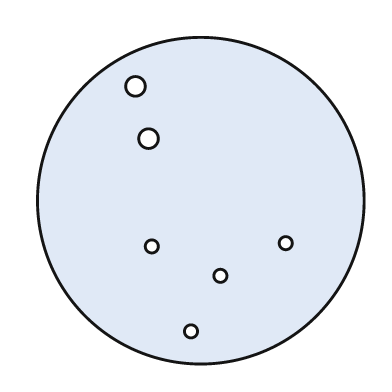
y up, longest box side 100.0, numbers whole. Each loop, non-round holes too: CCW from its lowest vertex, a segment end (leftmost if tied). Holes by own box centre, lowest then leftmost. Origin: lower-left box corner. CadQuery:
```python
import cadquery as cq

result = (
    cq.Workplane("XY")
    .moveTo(50.0, 50.0)
    .circle(50.0)
    .moveTo(47.0, 10.0)
    .circle(2.0)
    .moveTo(56.0, 27.0)
    .circle(2.0)
    .moveTo(35.0, 36.0)
    .circle(2.0)
    .moveTo(76.0, 37.0)
    .circle(2.0)
    .moveTo(34.0, 69.0)
    .circle(3.0)
    .moveTo(30.0, 85.0)
    .circle(3.0)
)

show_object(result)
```